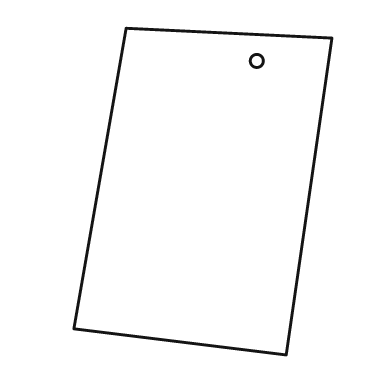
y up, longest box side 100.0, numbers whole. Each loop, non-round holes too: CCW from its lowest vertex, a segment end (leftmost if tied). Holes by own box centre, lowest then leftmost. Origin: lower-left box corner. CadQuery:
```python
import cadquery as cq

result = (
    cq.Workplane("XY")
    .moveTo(65.0, 0.0)
    .lineTo(79.0, 97.0)
    .lineTo(16.0, 100.0)
    .lineTo(0.0, 8.0)
    .close()
    .moveTo(56.0, 90.0)
    .circle(2.0)
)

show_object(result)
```